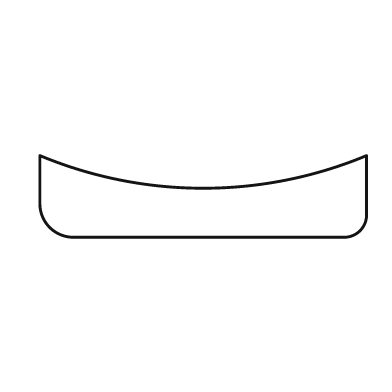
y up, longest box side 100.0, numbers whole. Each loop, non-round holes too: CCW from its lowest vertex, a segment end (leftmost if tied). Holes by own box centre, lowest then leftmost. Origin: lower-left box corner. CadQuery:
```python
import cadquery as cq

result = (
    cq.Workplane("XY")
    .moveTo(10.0, 0.0)
    .lineTo(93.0, 0.0)
    .threePointArc((98.0, 2.0), (100.0, 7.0))
    .lineTo(100.0, 25.0)
    .threePointArc((50.0, 15.0), (0.0, 25.0))
    .lineTo(0.0, 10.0)
    .threePointArc((3.0, 3.0), (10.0, 0.0))
    .close()
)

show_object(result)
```